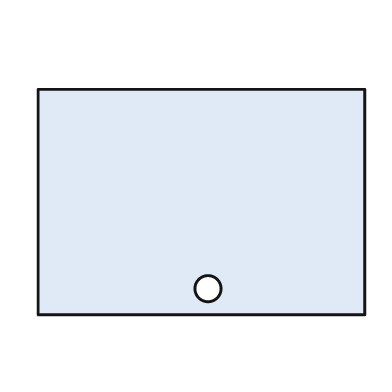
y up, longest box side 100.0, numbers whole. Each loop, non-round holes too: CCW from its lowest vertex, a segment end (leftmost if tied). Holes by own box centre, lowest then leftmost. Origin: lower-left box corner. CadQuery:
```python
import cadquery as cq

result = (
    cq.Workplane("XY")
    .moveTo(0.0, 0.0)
    .lineTo(100.0, 0.0)
    .lineTo(100.0, 69.0)
    .lineTo(0.0, 69.0)
    .close()
    .moveTo(52.0, 8.0)
    .circle(4.0)
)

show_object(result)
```